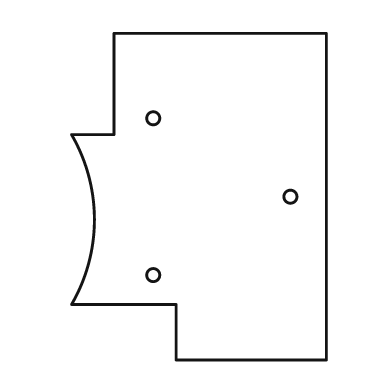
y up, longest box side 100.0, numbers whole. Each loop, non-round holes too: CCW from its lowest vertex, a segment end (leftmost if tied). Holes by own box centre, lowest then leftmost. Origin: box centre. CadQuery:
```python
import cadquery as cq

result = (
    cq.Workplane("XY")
    .moveTo(-7.0, -50.0)
    .lineTo(39.0, -50.0)
    .lineTo(39.0, 50.0)
    .lineTo(-26.0, 50.0)
    .lineTo(-26.0, 19.0)
    .lineTo(-39.0, 19.0)
    .threePointArc((-32.0, -7.0), (-39.0, -33.0))
    .lineTo(-7.0, -33.0)
    .close()
    .moveTo(-14.0, -24.0)
    .circle(2.0)
    .moveTo(28.0, 0.0)
    .circle(2.0)
    .moveTo(-14.0, 24.0)
    .circle(2.0)
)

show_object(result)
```